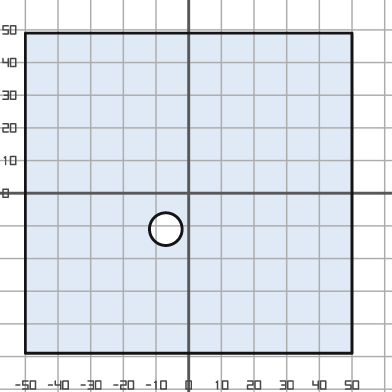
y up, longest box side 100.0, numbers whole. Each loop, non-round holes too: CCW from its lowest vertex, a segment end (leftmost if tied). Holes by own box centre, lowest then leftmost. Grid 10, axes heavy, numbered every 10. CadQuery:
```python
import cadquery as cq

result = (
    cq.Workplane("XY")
    .moveTo(-50.0, -49.0)
    .lineTo(50.0, -49.0)
    .lineTo(50.0, 49.0)
    .lineTo(-50.0, 49.0)
    .close()
    .moveTo(-7.0, -11.0)
    .circle(5.0)
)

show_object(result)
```